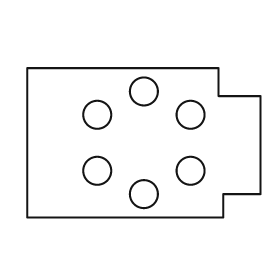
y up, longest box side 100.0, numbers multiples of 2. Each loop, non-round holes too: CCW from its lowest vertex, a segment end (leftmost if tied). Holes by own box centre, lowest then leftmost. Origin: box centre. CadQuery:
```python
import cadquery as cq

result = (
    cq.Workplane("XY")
    .moveTo(-50.0, -32.0)
    .lineTo(34.0, -32.0)
    .lineTo(34.0, -22.0)
    .lineTo(50.0, -22.0)
    .lineTo(50.0, 20.0)
    .lineTo(32.0, 20.0)
    .lineTo(32.0, 32.0)
    .lineTo(-50.0, 32.0)
    .close()
    .moveTo(0.0, -22.0)
    .circle(6.0)
    .moveTo(-20.0, -12.0)
    .circle(6.0)
    .moveTo(20.0, -12.0)
    .circle(6.0)
    .moveTo(-20.0, 12.0)
    .circle(6.0)
    .moveTo(20.0, 12.0)
    .circle(6.0)
    .moveTo(0.0, 22.0)
    .circle(6.0)
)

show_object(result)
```